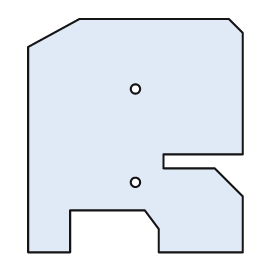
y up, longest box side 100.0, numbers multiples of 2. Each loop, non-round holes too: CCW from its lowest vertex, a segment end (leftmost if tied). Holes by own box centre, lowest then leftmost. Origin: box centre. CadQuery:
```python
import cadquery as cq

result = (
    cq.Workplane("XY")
    .moveTo(-46.0, -50.0)
    .lineTo(-28.0, -50.0)
    .lineTo(-28.0, -32.0)
    .lineTo(4.0, -32.0)
    .lineTo(10.0, -40.0)
    .lineTo(10.0, -50.0)
    .lineTo(46.0, -50.0)
    .lineTo(46.0, -26.0)
    .lineTo(34.0, -14.0)
    .lineTo(12.0, -14.0)
    .lineTo(12.0, -8.0)
    .lineTo(46.0, -8.0)
    .lineTo(46.0, 44.0)
    .lineTo(40.0, 50.0)
    .lineTo(-24.0, 50.0)
    .lineTo(-46.0, 38.0)
    .close()
    .moveTo(0.0, -20.0)
    .circle(2.0)
    .moveTo(0.0, 20.0)
    .circle(2.0)
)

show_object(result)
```